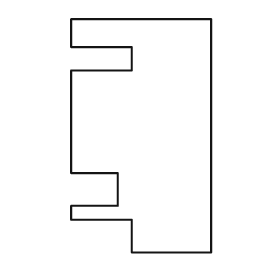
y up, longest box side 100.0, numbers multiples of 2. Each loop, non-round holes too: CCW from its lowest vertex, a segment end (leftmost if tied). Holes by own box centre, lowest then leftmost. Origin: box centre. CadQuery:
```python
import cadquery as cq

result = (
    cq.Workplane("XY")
    .moveTo(-4.0, -50.0)
    .lineTo(30.0, -50.0)
    .lineTo(30.0, 50.0)
    .lineTo(-30.0, 50.0)
    .lineTo(-30.0, 38.0)
    .lineTo(-4.0, 38.0)
    .lineTo(-4.0, 28.0)
    .lineTo(-30.0, 28.0)
    .lineTo(-30.0, -16.0)
    .lineTo(-10.0, -16.0)
    .lineTo(-10.0, -30.0)
    .lineTo(-30.0, -30.0)
    .lineTo(-30.0, -36.0)
    .lineTo(-4.0, -36.0)
    .close()
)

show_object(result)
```